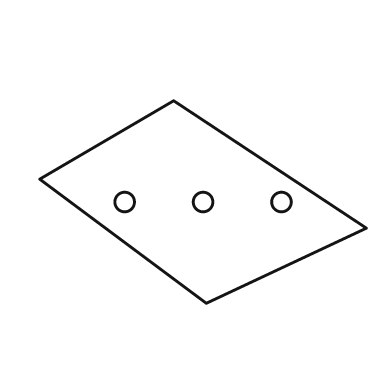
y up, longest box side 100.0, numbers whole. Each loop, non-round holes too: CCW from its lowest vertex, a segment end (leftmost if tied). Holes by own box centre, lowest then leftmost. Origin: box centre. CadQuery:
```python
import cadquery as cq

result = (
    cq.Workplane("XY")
    .moveTo(1.0, -31.0)
    .lineTo(50.0, -8.0)
    .lineTo(-9.0, 31.0)
    .lineTo(-50.0, 7.0)
    .close()
    .moveTo(-24.0, 0.0)
    .circle(3.0)
    .moveTo(0.0, 0.0)
    .circle(3.0)
    .moveTo(24.0, 0.0)
    .circle(3.0)
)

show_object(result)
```